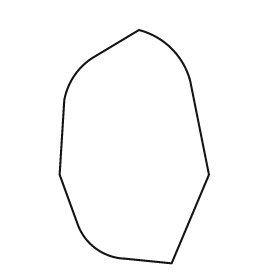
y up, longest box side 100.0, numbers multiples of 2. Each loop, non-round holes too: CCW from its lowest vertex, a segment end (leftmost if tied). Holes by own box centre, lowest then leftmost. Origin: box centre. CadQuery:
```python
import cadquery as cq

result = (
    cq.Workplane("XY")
    .moveTo(16.0, -50.0)
    .lineTo(32.0, -12.0)
    .lineTo(24.0, 28.0)
    .threePointArc((16.0, 42.0), (2.0, 50.0))
    .lineTo(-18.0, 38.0)
    .threePointArc((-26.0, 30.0), (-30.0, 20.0))
    .lineTo(-32.0, -12.0)
    .lineTo(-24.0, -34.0)
    .threePointArc((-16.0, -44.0), (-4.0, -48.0))
    .close()
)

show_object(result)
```